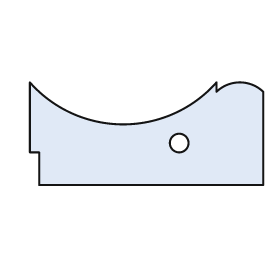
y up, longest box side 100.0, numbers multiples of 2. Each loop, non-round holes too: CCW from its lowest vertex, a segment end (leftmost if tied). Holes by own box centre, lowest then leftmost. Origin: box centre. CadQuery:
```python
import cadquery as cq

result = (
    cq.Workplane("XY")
    .moveTo(-46.0, -22.0)
    .lineTo(50.0, -22.0)
    .lineTo(50.0, 18.0)
    .threePointArc((40.0, 22.0), (30.0, 18.0))
    .lineTo(30.0, 22.0)
    .threePointArc((-10.0, 4.0), (-50.0, 22.0))
    .lineTo(-50.0, -8.0)
    .lineTo(-46.0, -8.0)
    .close()
    .moveTo(14.0, -4.0)
    .circle(4.0)
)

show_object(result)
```